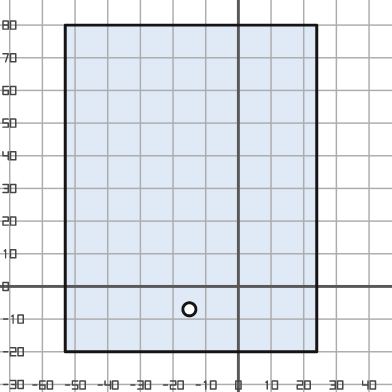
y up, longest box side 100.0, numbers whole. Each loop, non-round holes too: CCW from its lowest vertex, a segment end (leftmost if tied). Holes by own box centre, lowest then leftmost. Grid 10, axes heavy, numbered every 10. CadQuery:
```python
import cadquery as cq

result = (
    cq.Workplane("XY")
    .moveTo(-53.0, -20.0)
    .lineTo(24.0, -20.0)
    .lineTo(24.0, 80.0)
    .lineTo(-53.0, 80.0)
    .close()
    .moveTo(-15.0, -7.0)
    .circle(2.0)
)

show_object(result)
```